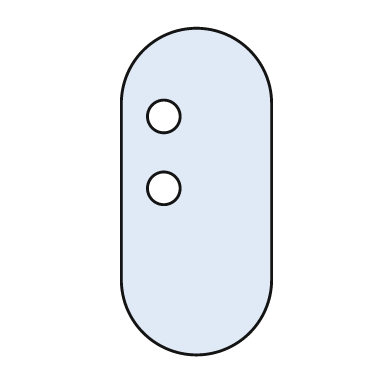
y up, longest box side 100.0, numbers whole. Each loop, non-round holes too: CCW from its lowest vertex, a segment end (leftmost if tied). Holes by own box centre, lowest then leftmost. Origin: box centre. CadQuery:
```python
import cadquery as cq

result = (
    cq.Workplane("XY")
    .moveTo(-23.0, -27.0)
    .threePointArc((0.0, -50.0), (23.0, -27.0))
    .lineTo(23.0, 27.0)
    .threePointArc((0.0, 50.0), (-23.0, 27.0))
    .close()
    .moveTo(-10.0, 1.0)
    .circle(5.0)
    .moveTo(-10.0, 23.0)
    .circle(5.0)
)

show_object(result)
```